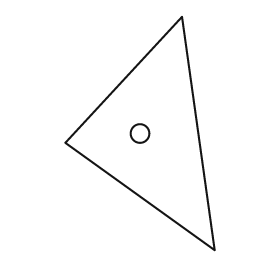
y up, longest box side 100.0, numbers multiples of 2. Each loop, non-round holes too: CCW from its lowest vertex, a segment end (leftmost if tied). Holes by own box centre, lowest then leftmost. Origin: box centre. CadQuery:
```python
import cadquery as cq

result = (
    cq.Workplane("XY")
    .moveTo(32.0, -50.0)
    .lineTo(18.0, 50.0)
    .lineTo(-32.0, -4.0)
    .close()
    .moveTo(0.0, 0.0)
    .circle(4.0)
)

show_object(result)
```